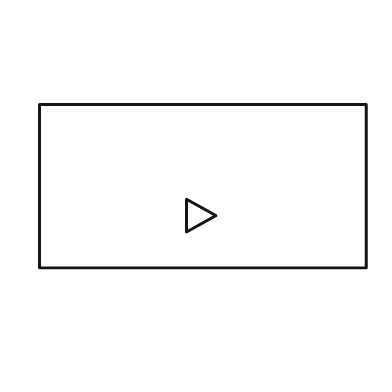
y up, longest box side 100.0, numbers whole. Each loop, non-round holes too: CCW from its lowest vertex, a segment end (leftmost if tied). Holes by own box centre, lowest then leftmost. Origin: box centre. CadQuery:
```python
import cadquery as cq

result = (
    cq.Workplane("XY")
    .moveTo(-50.0, -25.0)
    .lineTo(50.0, -25.0)
    .lineTo(50.0, 25.0)
    .lineTo(-50.0, 25.0)
    .close()
    .moveTo(-5.0, -14.0)
    .lineTo(4.0, -9.0)
    .lineTo(-5.0, -4.0)
    .close()
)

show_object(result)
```